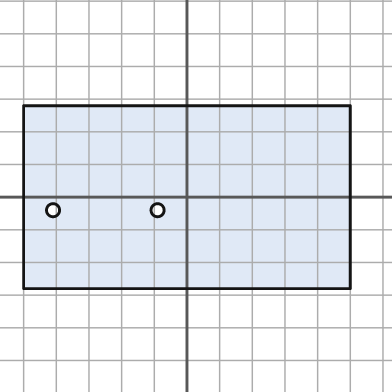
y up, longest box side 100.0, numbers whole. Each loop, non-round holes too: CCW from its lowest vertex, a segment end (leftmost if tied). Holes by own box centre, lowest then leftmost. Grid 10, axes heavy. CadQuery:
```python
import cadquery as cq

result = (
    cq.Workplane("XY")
    .moveTo(-50.0, -28.0)
    .lineTo(50.0, -28.0)
    .lineTo(50.0, 28.0)
    .lineTo(-50.0, 28.0)
    .close()
    .moveTo(-41.0, -4.0)
    .circle(2.0)
    .moveTo(-9.0, -4.0)
    .circle(2.0)
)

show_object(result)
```